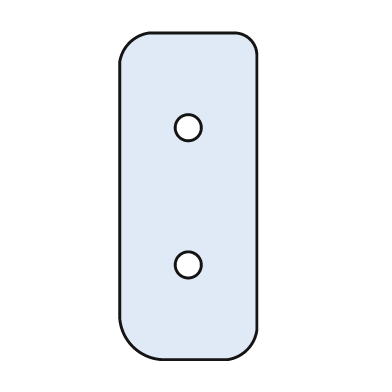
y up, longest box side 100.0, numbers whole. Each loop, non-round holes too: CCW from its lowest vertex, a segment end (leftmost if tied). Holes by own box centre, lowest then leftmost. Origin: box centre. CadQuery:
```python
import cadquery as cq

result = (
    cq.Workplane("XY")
    .moveTo(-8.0, -50.0)
    .lineTo(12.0, -50.0)
    .threePointArc((18.0, -47.0), (21.0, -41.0))
    .lineTo(21.0, 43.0)
    .threePointArc((19.0, 48.0), (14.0, 50.0))
    .lineTo(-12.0, 50.0)
    .threePointArc((-18.0, 47.0), (-21.0, 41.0))
    .lineTo(-21.0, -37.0)
    .threePointArc((-17.0, -46.0), (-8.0, -50.0))
    .close()
    .moveTo(0.0, -21.0)
    .circle(4.0)
    .moveTo(0.0, 21.0)
    .circle(4.0)
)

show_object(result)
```